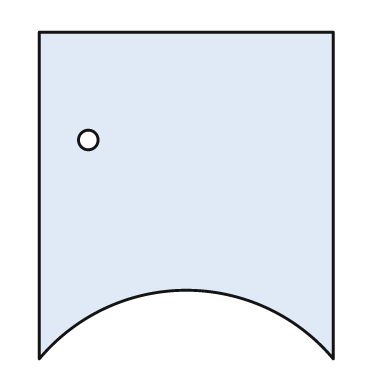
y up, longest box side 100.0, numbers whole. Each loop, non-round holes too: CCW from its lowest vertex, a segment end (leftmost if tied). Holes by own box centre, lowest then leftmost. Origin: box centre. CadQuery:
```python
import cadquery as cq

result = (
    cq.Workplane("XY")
    .moveTo(-45.0, -50.0)
    .threePointArc((0.0, -29.0), (45.0, -50.0))
    .lineTo(45.0, 50.0)
    .lineTo(-45.0, 50.0)
    .close()
    .moveTo(-30.0, 17.0)
    .circle(3.0)
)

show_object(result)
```